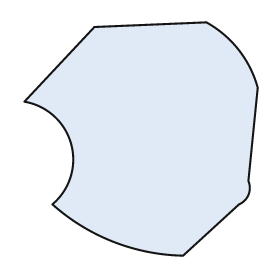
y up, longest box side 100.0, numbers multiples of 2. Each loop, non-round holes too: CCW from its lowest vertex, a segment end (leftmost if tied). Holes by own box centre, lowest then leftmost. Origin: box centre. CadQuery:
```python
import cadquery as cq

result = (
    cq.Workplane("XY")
    .moveTo(18.0, -50.0)
    .lineTo(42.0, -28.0)
    .threePointArc((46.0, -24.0), (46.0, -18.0))
    .lineTo(50.0, 22.0)
    .threePointArc((42.0, 38.0), (28.0, 50.0))
    .lineTo(-20.0, 48.0)
    .lineTo(-50.0, 16.0)
    .threePointArc((-30.0, -2.0), (-38.0, -28.0))
    .threePointArc((-12.0, -44.0), (18.0, -50.0))
    .close()
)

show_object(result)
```